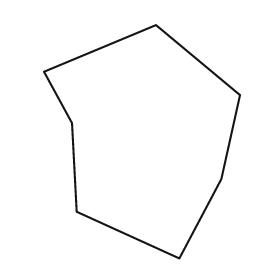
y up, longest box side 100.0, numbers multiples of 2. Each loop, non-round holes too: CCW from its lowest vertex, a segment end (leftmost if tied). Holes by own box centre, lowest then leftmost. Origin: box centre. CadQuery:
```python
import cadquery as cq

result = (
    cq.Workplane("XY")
    .moveTo(16.0, -50.0)
    .lineTo(34.0, -16.0)
    .lineTo(42.0, 20.0)
    .lineTo(6.0, 50.0)
    .lineTo(-42.0, 30.0)
    .lineTo(-30.0, 8.0)
    .lineTo(-28.0, -30.0)
    .close()
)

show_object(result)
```